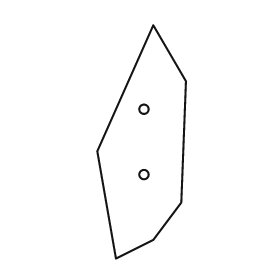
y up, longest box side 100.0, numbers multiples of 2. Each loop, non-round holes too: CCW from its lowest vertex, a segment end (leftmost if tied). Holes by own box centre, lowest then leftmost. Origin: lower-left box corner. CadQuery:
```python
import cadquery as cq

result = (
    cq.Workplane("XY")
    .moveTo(8.0, 0.0)
    .lineTo(24.0, 8.0)
    .lineTo(36.0, 24.0)
    .lineTo(38.0, 76.0)
    .lineTo(24.0, 100.0)
    .lineTo(0.0, 46.0)
    .close()
    .moveTo(20.0, 36.0)
    .circle(2.0)
    .moveTo(20.0, 64.0)
    .circle(2.0)
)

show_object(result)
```